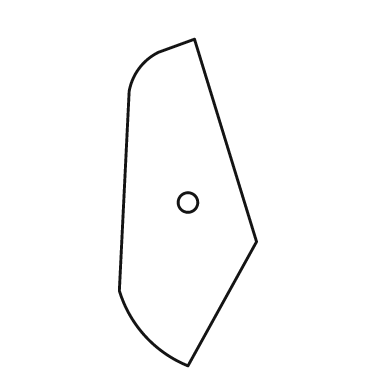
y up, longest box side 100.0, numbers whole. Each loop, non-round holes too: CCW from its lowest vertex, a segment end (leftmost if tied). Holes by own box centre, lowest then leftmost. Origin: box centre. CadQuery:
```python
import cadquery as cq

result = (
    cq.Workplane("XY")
    .moveTo(0.0, -50.0)
    .lineTo(21.0, -12.0)
    .lineTo(2.0, 50.0)
    .lineTo(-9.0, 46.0)
    .threePointArc((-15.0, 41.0), (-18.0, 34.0))
    .lineTo(-21.0, -27.0)
    .threePointArc((-13.0, -41.0), (0.0, -50.0))
    .close()
    .moveTo(0.0, 0.0)
    .circle(3.0)
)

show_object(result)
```